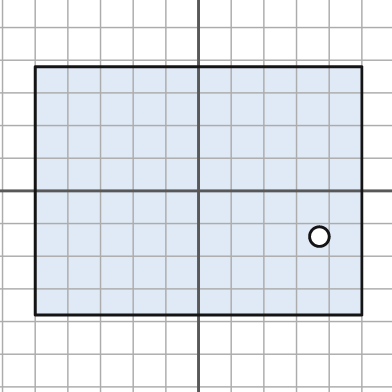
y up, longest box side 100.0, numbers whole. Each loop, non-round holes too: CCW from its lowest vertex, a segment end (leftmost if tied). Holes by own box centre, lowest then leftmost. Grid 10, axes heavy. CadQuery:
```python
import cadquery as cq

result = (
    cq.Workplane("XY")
    .moveTo(-50.0, -38.0)
    .lineTo(50.0, -38.0)
    .lineTo(50.0, 38.0)
    .lineTo(-50.0, 38.0)
    .close()
    .moveTo(37.0, -14.0)
    .circle(3.0)
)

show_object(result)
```